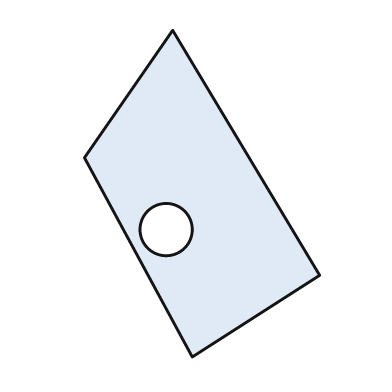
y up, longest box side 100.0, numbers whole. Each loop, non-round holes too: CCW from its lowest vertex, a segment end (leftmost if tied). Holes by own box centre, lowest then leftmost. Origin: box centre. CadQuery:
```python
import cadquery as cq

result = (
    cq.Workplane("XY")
    .moveTo(-3.0, -50.0)
    .lineTo(36.0, -25.0)
    .lineTo(-9.0, 50.0)
    .lineTo(-36.0, 11.0)
    .close()
    .moveTo(-11.0, -11.0)
    .circle(8.0)
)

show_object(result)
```